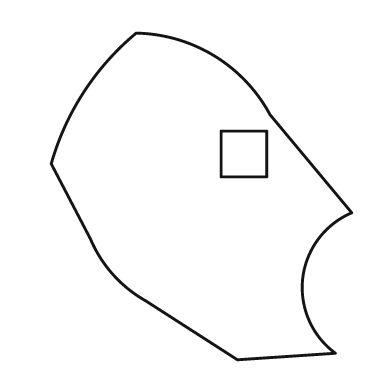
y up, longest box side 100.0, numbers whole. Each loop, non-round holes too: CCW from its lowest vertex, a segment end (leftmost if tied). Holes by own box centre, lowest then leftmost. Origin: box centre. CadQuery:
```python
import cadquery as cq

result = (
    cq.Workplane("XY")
    .moveTo(11.0, -50.0)
    .lineTo(41.0, -48.0)
    .threePointArc((31.0, -25.0), (46.0, -5.0))
    .lineTo(21.0, 25.0)
    .threePointArc((4.0, 43.0), (-20.0, 50.0))
    .threePointArc((-36.0, 32.0), (-46.0, 10.0))
    .lineTo(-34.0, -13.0)
    .threePointArc((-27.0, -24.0), (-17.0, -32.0))
    .close()
    .moveTo(6.0, 6.0)
    .lineTo(20.0, 6.0)
    .lineTo(20.0, 20.0)
    .lineTo(6.0, 20.0)
    .close()
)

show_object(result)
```